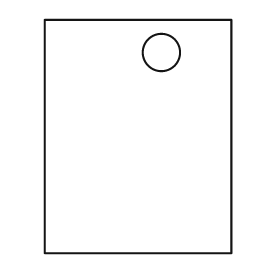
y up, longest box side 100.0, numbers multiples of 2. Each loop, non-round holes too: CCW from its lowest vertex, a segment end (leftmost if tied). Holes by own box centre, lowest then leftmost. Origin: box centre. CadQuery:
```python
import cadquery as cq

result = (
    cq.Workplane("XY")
    .moveTo(-40.0, -50.0)
    .lineTo(40.0, -50.0)
    .lineTo(40.0, 50.0)
    .lineTo(-40.0, 50.0)
    .close()
    .moveTo(10.0, 36.0)
    .circle(8.0)
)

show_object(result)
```